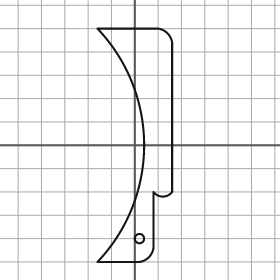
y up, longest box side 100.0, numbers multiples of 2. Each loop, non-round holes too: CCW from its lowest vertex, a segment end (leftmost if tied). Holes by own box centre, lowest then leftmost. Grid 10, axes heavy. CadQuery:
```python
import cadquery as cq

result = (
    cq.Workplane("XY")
    .moveTo(-16.0, -50.0)
    .lineTo(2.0, -50.0)
    .threePointArc((6.0, -48.0), (8.0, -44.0))
    .lineTo(8.0, -20.0)
    .threePointArc((12.0, -22.0), (16.0, -20.0))
    .lineTo(16.0, 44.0)
    .threePointArc((14.0, 48.0), (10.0, 50.0))
    .lineTo(-16.0, 50.0)
    .threePointArc((4.0, 0.0), (-16.0, -50.0))
    .close()
    .moveTo(2.0, -40.0)
    .circle(2.0)
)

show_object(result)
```